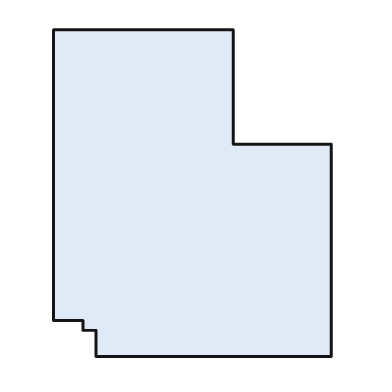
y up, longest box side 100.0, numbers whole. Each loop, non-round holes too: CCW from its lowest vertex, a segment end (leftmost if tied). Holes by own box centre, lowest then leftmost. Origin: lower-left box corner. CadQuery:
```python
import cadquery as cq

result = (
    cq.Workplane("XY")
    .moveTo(13.0, 0.0)
    .lineTo(85.0, 0.0)
    .lineTo(85.0, 65.0)
    .lineTo(55.0, 65.0)
    .lineTo(55.0, 100.0)
    .lineTo(0.0, 100.0)
    .lineTo(0.0, 11.0)
    .lineTo(9.0, 11.0)
    .lineTo(9.0, 8.0)
    .lineTo(13.0, 8.0)
    .close()
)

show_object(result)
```